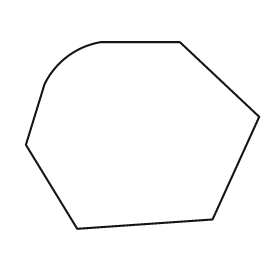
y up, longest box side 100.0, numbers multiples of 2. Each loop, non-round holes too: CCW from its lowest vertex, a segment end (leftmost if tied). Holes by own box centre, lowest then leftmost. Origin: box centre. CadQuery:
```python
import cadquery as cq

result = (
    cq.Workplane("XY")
    .moveTo(-28.0, -40.0)
    .lineTo(30.0, -36.0)
    .lineTo(50.0, 8.0)
    .lineTo(16.0, 40.0)
    .lineTo(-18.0, 40.0)
    .threePointArc((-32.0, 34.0), (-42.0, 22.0))
    .lineTo(-50.0, -4.0)
    .close()
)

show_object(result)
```